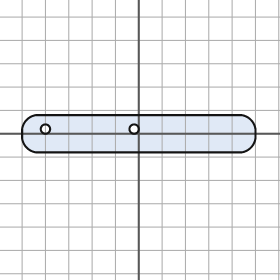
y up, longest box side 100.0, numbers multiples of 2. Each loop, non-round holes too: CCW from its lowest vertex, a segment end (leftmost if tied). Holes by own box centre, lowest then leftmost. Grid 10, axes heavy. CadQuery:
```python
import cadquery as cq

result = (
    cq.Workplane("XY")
    .moveTo(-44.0, -8.0)
    .lineTo(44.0, -8.0)
    .threePointArc((48.0, -6.0), (50.0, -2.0))
    .lineTo(50.0, 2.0)
    .threePointArc((48.0, 6.0), (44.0, 8.0))
    .lineTo(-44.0, 8.0)
    .threePointArc((-48.0, 6.0), (-50.0, 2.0))
    .lineTo(-50.0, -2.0)
    .threePointArc((-48.0, -6.0), (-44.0, -8.0))
    .close()
    .moveTo(-40.0, 2.0)
    .circle(2.0)
    .moveTo(-2.0, 2.0)
    .circle(2.0)
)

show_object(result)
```